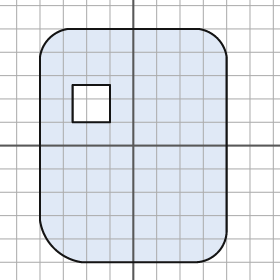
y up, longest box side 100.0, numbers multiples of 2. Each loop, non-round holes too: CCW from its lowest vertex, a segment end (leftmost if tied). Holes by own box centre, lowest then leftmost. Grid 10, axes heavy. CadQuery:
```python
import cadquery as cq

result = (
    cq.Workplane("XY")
    .moveTo(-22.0, -50.0)
    .lineTo(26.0, -50.0)
    .threePointArc((36.0, -46.0), (40.0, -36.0))
    .lineTo(40.0, 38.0)
    .threePointArc((36.0, 46.0), (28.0, 50.0))
    .lineTo(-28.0, 50.0)
    .threePointArc((-36.0, 46.0), (-40.0, 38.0))
    .lineTo(-40.0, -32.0)
    .threePointArc((-34.0, -44.0), (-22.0, -50.0))
    .close()
    .moveTo(-26.0, 10.0)
    .lineTo(-10.0, 10.0)
    .lineTo(-10.0, 26.0)
    .lineTo(-26.0, 26.0)
    .close()
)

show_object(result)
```